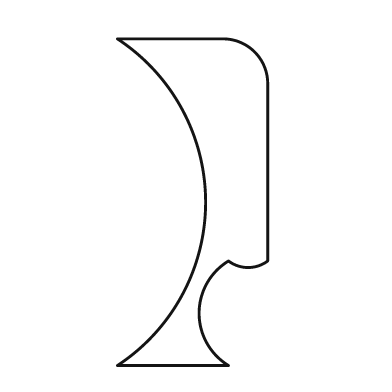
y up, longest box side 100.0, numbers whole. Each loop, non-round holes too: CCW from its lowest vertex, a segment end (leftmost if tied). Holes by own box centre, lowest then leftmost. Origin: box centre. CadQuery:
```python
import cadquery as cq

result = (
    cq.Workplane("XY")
    .moveTo(-23.0, -50.0)
    .lineTo(11.0, -50.0)
    .threePointArc((2.0, -34.0), (11.0, -18.0))
    .threePointArc((17.0, -20.0), (23.0, -18.0))
    .lineTo(23.0, 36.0)
    .threePointArc((19.0, 46.0), (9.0, 50.0))
    .lineTo(-23.0, 50.0)
    .threePointArc((4.0, 0.0), (-23.0, -50.0))
    .close()
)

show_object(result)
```